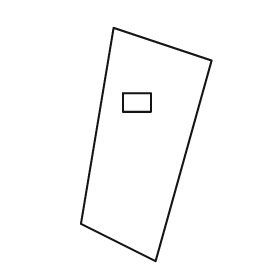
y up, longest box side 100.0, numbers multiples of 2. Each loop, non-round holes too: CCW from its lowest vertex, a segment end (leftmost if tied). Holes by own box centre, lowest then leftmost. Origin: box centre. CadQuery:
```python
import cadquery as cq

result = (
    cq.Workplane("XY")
    .moveTo(4.0, -50.0)
    .lineTo(28.0, 36.0)
    .lineTo(-14.0, 50.0)
    .lineTo(-28.0, -34.0)
    .close()
    .moveTo(-10.0, 14.0)
    .lineTo(2.0, 14.0)
    .lineTo(2.0, 22.0)
    .lineTo(-10.0, 22.0)
    .close()
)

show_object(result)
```